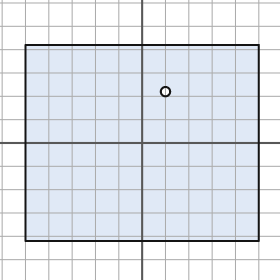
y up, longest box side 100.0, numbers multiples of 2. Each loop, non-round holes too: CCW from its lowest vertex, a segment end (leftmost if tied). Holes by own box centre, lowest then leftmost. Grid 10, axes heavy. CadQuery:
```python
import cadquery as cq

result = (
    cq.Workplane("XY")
    .moveTo(-50.0, -42.0)
    .lineTo(50.0, -42.0)
    .lineTo(50.0, 42.0)
    .lineTo(-50.0, 42.0)
    .close()
    .moveTo(10.0, 22.0)
    .circle(2.0)
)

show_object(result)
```